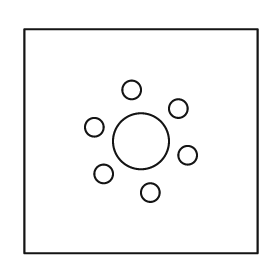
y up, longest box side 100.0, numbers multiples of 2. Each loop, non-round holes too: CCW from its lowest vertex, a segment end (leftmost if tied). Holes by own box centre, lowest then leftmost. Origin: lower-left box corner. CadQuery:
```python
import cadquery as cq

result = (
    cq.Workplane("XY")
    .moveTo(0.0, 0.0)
    .lineTo(100.0, 0.0)
    .lineTo(100.0, 96.0)
    .lineTo(0.0, 96.0)
    .close()
    .moveTo(54.0, 26.0)
    .circle(4.0)
    .moveTo(34.0, 34.0)
    .circle(4.0)
    .moveTo(70.0, 42.0)
    .circle(4.0)
    .moveTo(50.0, 48.0)
    .circle(12.0)
    .moveTo(30.0, 54.0)
    .circle(4.0)
    .moveTo(66.0, 62.0)
    .circle(4.0)
    .moveTo(46.0, 70.0)
    .circle(4.0)
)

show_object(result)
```